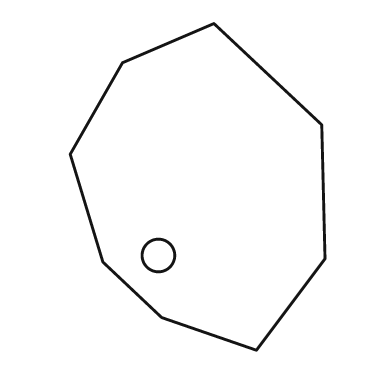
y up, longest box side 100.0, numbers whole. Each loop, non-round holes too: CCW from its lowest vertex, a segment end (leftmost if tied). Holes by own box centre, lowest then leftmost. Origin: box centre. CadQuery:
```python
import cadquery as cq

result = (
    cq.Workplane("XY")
    .moveTo(18.0, -50.0)
    .lineTo(39.0, -22.0)
    .lineTo(38.0, 19.0)
    .lineTo(5.0, 50.0)
    .lineTo(-23.0, 38.0)
    .lineTo(-39.0, 10.0)
    .lineTo(-29.0, -23.0)
    .lineTo(-11.0, -40.0)
    .close()
    .moveTo(-12.0, -21.0)
    .circle(5.0)
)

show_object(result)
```